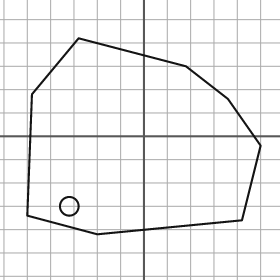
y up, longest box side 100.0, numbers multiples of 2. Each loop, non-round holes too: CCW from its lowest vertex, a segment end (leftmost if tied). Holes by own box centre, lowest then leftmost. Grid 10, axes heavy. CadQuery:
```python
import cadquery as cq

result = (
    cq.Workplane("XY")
    .moveTo(-20.0, -42.0)
    .lineTo(42.0, -36.0)
    .lineTo(50.0, -4.0)
    .lineTo(36.0, 16.0)
    .lineTo(18.0, 30.0)
    .lineTo(-28.0, 42.0)
    .lineTo(-48.0, 18.0)
    .lineTo(-50.0, -34.0)
    .close()
    .moveTo(-32.0, -30.0)
    .circle(4.0)
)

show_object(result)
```